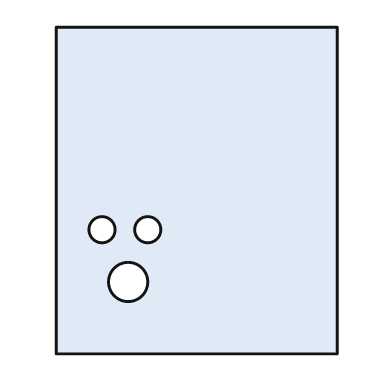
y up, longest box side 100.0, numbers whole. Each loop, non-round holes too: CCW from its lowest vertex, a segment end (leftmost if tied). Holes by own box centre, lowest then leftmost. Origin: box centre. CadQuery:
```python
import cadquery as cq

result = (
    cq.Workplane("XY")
    .moveTo(-43.0, -50.0)
    .lineTo(43.0, -50.0)
    .lineTo(43.0, 50.0)
    .lineTo(-43.0, 50.0)
    .close()
    .moveTo(-21.0, -28.0)
    .circle(6.0)
    .moveTo(-29.0, -12.0)
    .circle(4.0)
    .moveTo(-15.0, -12.0)
    .circle(4.0)
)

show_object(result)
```